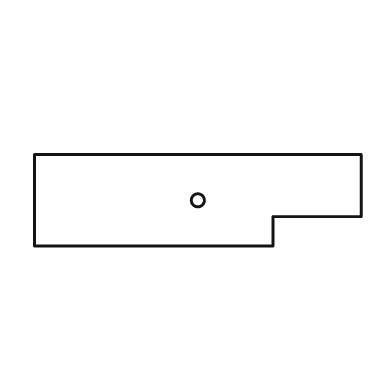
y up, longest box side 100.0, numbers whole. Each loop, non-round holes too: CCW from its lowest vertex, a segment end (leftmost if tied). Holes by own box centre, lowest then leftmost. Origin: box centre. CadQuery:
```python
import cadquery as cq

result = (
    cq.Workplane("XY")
    .moveTo(-50.0, -14.0)
    .lineTo(23.0, -14.0)
    .lineTo(23.0, -5.0)
    .lineTo(50.0, -5.0)
    .lineTo(50.0, 14.0)
    .lineTo(-50.0, 14.0)
    .close()
    .moveTo(0.0, 0.0)
    .circle(2.0)
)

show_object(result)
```